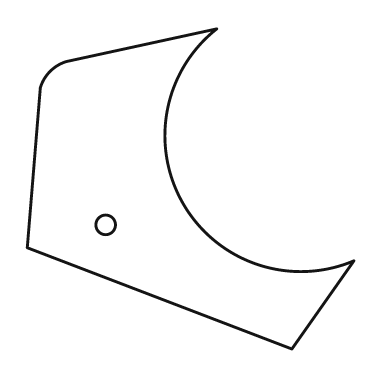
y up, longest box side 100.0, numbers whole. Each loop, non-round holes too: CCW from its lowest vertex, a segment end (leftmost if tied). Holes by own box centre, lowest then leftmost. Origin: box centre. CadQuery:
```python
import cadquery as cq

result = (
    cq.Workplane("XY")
    .moveTo(31.0, -49.0)
    .lineTo(50.0, -22.0)
    .threePointArc((-2.0, -5.0), (8.0, 49.0))
    .lineTo(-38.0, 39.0)
    .threePointArc((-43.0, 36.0), (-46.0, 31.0))
    .lineTo(-50.0, -18.0)
    .close()
    .moveTo(-26.0, -11.0)
    .circle(3.0)
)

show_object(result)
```